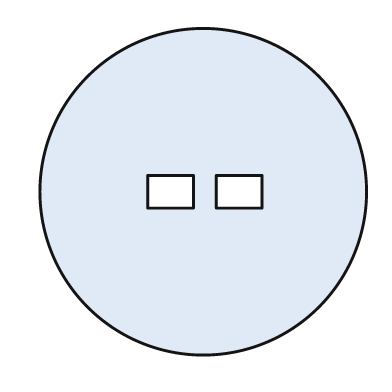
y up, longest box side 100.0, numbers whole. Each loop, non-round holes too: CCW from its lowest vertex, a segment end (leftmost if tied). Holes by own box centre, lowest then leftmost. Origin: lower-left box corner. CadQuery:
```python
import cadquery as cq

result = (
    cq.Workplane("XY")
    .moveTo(50.0, 50.0)
    .circle(50.0)
    .moveTo(33.0, 45.0)
    .lineTo(47.0, 45.0)
    .lineTo(47.0, 55.0)
    .lineTo(33.0, 55.0)
    .close()
    .moveTo(54.0, 45.0)
    .lineTo(68.0, 45.0)
    .lineTo(68.0, 55.0)
    .lineTo(54.0, 55.0)
    .close()
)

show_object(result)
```